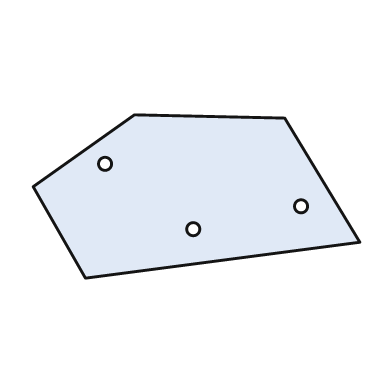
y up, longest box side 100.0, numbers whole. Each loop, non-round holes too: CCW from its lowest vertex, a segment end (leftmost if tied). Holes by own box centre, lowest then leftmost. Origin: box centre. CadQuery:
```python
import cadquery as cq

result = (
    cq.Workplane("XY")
    .moveTo(-34.0, -25.0)
    .lineTo(50.0, -14.0)
    .lineTo(27.0, 24.0)
    .lineTo(-19.0, 25.0)
    .lineTo(-50.0, 3.0)
    .close()
    .moveTo(-1.0, -10.0)
    .circle(2.0)
    .moveTo(32.0, -3.0)
    .circle(2.0)
    .moveTo(-28.0, 10.0)
    .circle(2.0)
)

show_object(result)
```